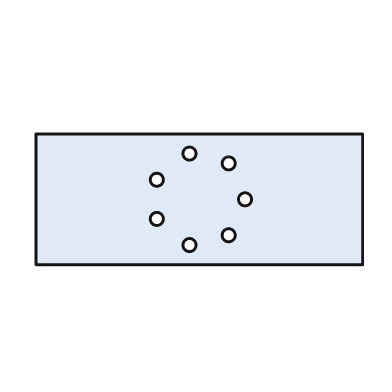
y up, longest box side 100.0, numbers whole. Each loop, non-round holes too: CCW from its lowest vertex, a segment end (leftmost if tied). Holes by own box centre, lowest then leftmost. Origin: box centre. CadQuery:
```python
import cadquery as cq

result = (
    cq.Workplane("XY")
    .moveTo(-50.0, -20.0)
    .lineTo(50.0, -20.0)
    .lineTo(50.0, 20.0)
    .lineTo(-50.0, 20.0)
    .close()
    .moveTo(-3.0, -14.0)
    .circle(2.0)
    .moveTo(9.0, -11.0)
    .circle(2.0)
    .moveTo(-13.0, -6.0)
    .circle(2.0)
    .moveTo(14.0, 0.0)
    .circle(2.0)
    .moveTo(-13.0, 6.0)
    .circle(2.0)
    .moveTo(9.0, 11.0)
    .circle(2.0)
    .moveTo(-3.0, 14.0)
    .circle(2.0)
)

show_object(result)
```